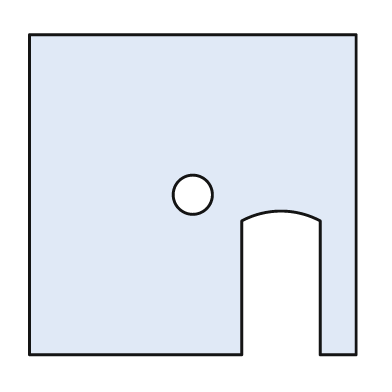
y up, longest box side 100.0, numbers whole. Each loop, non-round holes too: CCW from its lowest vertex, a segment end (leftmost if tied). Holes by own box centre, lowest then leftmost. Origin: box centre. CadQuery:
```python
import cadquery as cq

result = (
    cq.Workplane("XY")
    .moveTo(-50.0, -49.0)
    .lineTo(15.0, -49.0)
    .lineTo(15.0, -8.0)
    .threePointArc((27.0, -5.0), (39.0, -8.0))
    .lineTo(39.0, -49.0)
    .lineTo(50.0, -49.0)
    .lineTo(50.0, 49.0)
    .lineTo(-50.0, 49.0)
    .close()
    .moveTo(0.0, 0.0)
    .circle(6.0)
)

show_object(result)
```